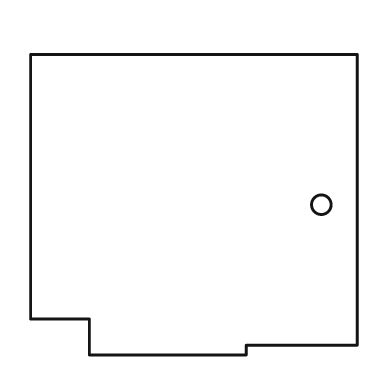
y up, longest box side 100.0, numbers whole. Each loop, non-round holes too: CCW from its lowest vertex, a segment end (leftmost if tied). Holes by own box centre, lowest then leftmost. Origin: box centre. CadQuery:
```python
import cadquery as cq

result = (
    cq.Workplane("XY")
    .moveTo(-32.0, -46.0)
    .lineTo(16.0, -46.0)
    .lineTo(16.0, -43.0)
    .lineTo(50.0, -43.0)
    .lineTo(50.0, 46.0)
    .lineTo(-50.0, 46.0)
    .lineTo(-50.0, -35.0)
    .lineTo(-32.0, -35.0)
    .close()
    .moveTo(39.0, 0.0)
    .circle(3.0)
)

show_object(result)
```